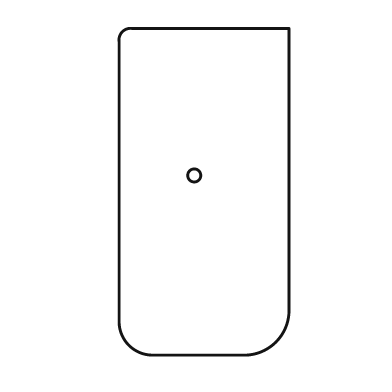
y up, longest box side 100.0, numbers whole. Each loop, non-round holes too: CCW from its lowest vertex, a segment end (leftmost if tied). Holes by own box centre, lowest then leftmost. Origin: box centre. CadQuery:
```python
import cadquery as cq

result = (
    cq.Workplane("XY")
    .moveTo(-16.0, -50.0)
    .lineTo(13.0, -50.0)
    .threePointArc((22.0, -46.0), (26.0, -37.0))
    .lineTo(26.0, 50.0)
    .lineTo(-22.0, 50.0)
    .threePointArc((-25.0, 49.0), (-26.0, 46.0))
    .lineTo(-26.0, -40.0)
    .threePointArc((-23.0, -47.0), (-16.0, -50.0))
    .close()
    .moveTo(-3.0, 5.0)
    .circle(2.0)
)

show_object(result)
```